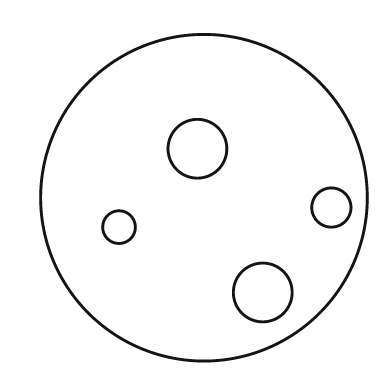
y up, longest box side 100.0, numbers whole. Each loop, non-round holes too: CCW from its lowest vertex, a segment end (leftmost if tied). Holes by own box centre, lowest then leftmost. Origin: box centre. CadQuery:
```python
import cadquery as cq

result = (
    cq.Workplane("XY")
    .moveTo(0.0, 0.0)
    .circle(50.0)
    .moveTo(18.0, -29.0)
    .circle(9.0)
    .moveTo(-26.0, -9.0)
    .circle(5.0)
    .moveTo(39.0, -3.0)
    .circle(6.0)
    .moveTo(-2.0, 15.0)
    .circle(9.0)
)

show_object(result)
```